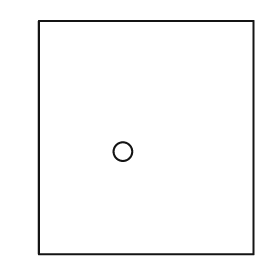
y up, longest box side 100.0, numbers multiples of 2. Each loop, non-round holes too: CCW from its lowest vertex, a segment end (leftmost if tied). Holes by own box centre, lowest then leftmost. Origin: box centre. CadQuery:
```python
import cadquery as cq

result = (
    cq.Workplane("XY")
    .moveTo(-46.0, -50.0)
    .lineTo(46.0, -50.0)
    .lineTo(46.0, 50.0)
    .lineTo(-46.0, 50.0)
    .close()
    .moveTo(-10.0, -6.0)
    .circle(4.0)
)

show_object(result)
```